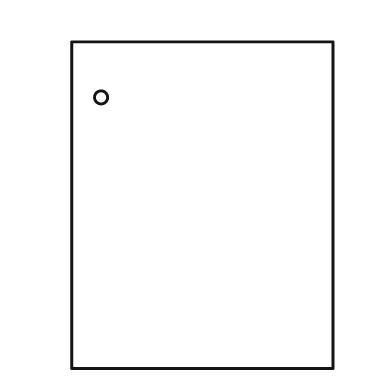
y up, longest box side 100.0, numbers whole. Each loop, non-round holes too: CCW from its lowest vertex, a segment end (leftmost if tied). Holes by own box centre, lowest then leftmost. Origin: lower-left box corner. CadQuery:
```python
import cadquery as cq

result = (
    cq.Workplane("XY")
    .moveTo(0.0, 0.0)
    .lineTo(80.0, 0.0)
    .lineTo(80.0, 100.0)
    .lineTo(0.0, 100.0)
    .close()
    .moveTo(9.0, 83.0)
    .circle(2.0)
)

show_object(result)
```